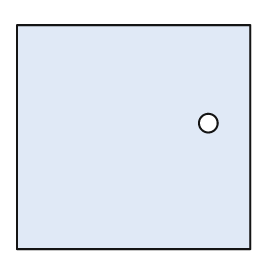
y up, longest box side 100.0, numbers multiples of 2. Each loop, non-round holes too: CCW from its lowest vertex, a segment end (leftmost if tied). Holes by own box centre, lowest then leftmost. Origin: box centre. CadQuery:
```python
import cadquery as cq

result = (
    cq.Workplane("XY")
    .moveTo(-50.0, -48.0)
    .lineTo(50.0, -48.0)
    .lineTo(50.0, 48.0)
    .lineTo(-50.0, 48.0)
    .close()
    .moveTo(32.0, 6.0)
    .circle(4.0)
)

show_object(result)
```